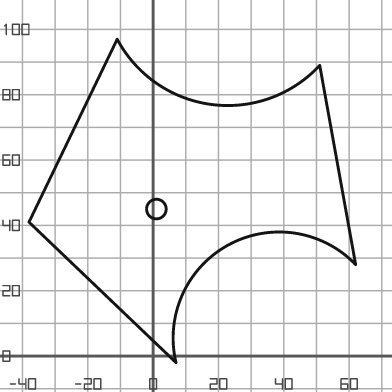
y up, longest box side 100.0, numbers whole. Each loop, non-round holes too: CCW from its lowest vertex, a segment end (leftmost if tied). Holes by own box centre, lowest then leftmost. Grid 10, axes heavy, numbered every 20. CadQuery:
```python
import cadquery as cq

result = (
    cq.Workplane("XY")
    .moveTo(7.0, -2.0)
    .threePointArc((23.0, 34.0), (62.0, 28.0))
    .lineTo(51.0, 89.0)
    .threePointArc((18.0, 77.0), (-11.0, 97.0))
    .lineTo(-38.0, 41.0)
    .close()
    .moveTo(1.0, 45.0)
    .circle(3.0)
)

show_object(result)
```